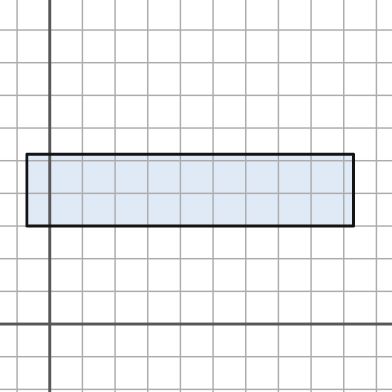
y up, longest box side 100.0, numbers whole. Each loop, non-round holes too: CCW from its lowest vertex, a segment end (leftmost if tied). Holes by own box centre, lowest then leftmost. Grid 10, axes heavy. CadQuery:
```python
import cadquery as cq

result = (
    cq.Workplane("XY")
    .moveTo(-7.0, 30.0)
    .lineTo(93.0, 30.0)
    .lineTo(93.0, 52.0)
    .lineTo(-7.0, 52.0)
    .close()
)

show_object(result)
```